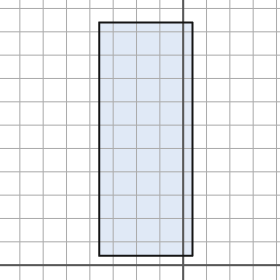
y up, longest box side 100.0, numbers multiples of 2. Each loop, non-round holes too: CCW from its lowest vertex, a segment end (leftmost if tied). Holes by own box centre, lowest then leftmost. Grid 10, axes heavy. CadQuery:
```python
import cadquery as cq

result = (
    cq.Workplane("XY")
    .moveTo(-36.0, 4.0)
    .lineTo(4.0, 4.0)
    .lineTo(4.0, 104.0)
    .lineTo(-36.0, 104.0)
    .close()
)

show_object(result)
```